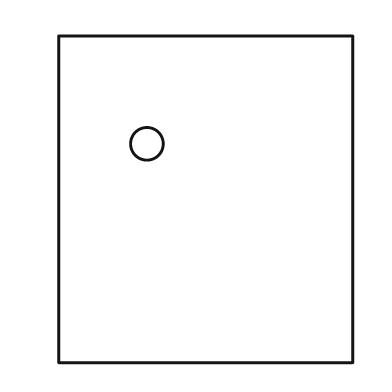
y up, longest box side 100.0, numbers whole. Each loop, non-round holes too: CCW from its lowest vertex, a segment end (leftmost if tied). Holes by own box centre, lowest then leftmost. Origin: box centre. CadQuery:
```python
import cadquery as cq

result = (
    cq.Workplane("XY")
    .moveTo(-45.0, -50.0)
    .lineTo(45.0, -50.0)
    .lineTo(45.0, 50.0)
    .lineTo(-45.0, 50.0)
    .close()
    .moveTo(-18.0, 17.0)
    .circle(5.0)
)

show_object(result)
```